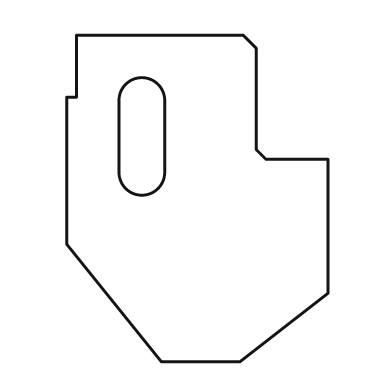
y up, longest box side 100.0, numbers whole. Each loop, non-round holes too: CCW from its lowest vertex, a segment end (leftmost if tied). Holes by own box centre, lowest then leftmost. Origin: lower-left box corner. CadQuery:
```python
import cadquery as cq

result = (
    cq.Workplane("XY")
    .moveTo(29.0, 0.0)
    .lineTo(53.0, 0.0)
    .lineTo(80.0, 21.0)
    .lineTo(80.0, 62.0)
    .lineTo(61.0, 62.0)
    .lineTo(58.0, 65.0)
    .lineTo(58.0, 96.0)
    .lineTo(54.0, 100.0)
    .lineTo(3.0, 100.0)
    .lineTo(3.0, 81.0)
    .lineTo(0.0, 81.0)
    .lineTo(0.0, 36.0)
    .close()
    .moveTo(16.0, 58.0)
    .threePointArc((23.0, 51.0), (30.0, 58.0))
    .lineTo(30.0, 80.0)
    .threePointArc((23.0, 87.0), (16.0, 80.0))
    .close()
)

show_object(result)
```